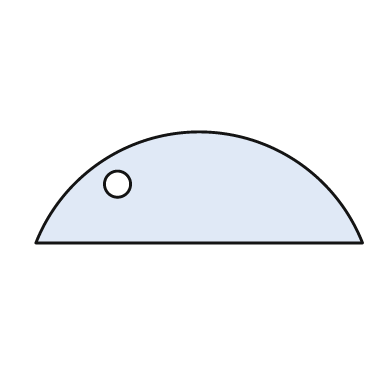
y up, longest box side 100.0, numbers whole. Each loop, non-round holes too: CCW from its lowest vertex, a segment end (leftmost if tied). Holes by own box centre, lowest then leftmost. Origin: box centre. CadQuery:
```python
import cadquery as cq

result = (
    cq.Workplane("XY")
    .moveTo(-50.0, -17.0)
    .lineTo(50.0, -17.0)
    .threePointArc((0.0, 17.0), (-50.0, -17.0))
    .close()
    .moveTo(-25.0, 1.0)
    .circle(4.0)
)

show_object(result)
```